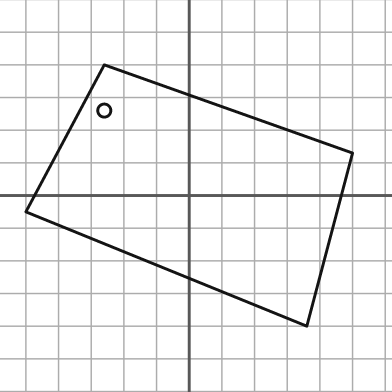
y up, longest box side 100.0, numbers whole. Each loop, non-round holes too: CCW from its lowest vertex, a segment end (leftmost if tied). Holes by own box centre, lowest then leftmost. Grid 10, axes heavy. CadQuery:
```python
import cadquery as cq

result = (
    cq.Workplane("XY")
    .moveTo(36.0, -40.0)
    .lineTo(50.0, 13.0)
    .lineTo(-26.0, 40.0)
    .lineTo(-50.0, -5.0)
    .close()
    .moveTo(-26.0, 26.0)
    .circle(2.0)
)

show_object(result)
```